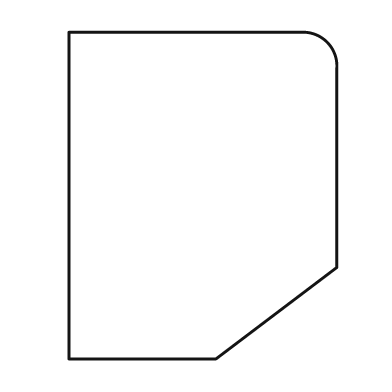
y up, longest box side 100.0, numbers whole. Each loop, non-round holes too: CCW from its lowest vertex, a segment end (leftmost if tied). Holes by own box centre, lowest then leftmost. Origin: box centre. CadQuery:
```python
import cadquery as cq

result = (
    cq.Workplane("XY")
    .moveTo(-41.0, -50.0)
    .lineTo(4.0, -50.0)
    .lineTo(41.0, -22.0)
    .lineTo(41.0, 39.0)
    .threePointArc((38.0, 47.0), (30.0, 50.0))
    .lineTo(-41.0, 50.0)
    .close()
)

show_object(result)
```